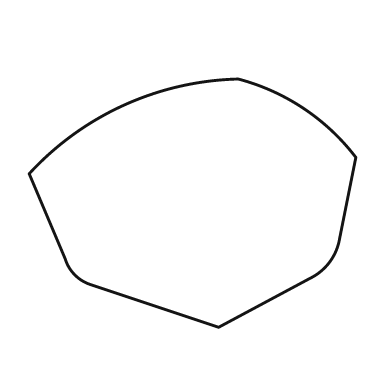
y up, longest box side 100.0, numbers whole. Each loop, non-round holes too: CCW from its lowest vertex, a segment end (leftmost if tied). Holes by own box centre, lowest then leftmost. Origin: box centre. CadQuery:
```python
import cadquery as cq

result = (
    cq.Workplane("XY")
    .moveTo(8.0, -38.0)
    .lineTo(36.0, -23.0)
    .threePointArc((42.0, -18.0), (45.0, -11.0))
    .lineTo(50.0, 14.0)
    .threePointArc((34.0, 29.0), (14.0, 38.0))
    .threePointArc((-21.0, 30.0), (-50.0, 9.0))
    .lineTo(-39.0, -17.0)
    .threePointArc((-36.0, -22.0), (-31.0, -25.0))
    .close()
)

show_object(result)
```